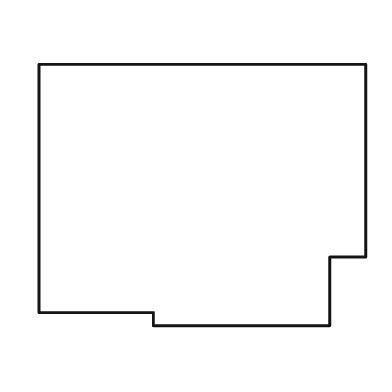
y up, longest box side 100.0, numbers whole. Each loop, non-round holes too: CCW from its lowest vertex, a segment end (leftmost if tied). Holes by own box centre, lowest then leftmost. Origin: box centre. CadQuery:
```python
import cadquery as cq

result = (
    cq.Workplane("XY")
    .moveTo(-15.0, -40.0)
    .lineTo(39.0, -40.0)
    .lineTo(39.0, -19.0)
    .lineTo(50.0, -19.0)
    .lineTo(50.0, 40.0)
    .lineTo(-50.0, 40.0)
    .lineTo(-50.0, -36.0)
    .lineTo(-15.0, -36.0)
    .close()
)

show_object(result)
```